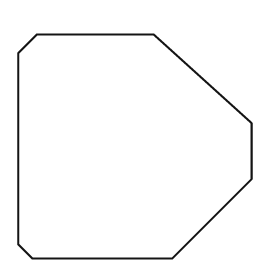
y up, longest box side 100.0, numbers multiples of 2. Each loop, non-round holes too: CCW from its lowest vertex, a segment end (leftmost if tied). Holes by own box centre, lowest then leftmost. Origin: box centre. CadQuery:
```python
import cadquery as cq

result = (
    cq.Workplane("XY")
    .moveTo(-44.0, -48.0)
    .lineTo(16.0, -48.0)
    .lineTo(50.0, -14.0)
    .lineTo(50.0, 10.0)
    .lineTo(8.0, 48.0)
    .lineTo(-42.0, 48.0)
    .lineTo(-50.0, 40.0)
    .lineTo(-50.0, -42.0)
    .close()
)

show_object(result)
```